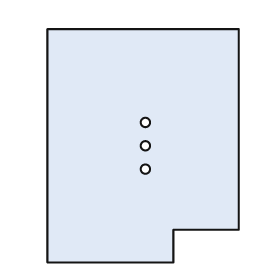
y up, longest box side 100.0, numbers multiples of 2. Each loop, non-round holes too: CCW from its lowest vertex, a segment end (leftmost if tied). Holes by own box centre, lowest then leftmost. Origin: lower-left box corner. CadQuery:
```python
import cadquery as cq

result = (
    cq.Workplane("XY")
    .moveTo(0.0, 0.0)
    .lineTo(54.0, 0.0)
    .lineTo(54.0, 14.0)
    .lineTo(82.0, 14.0)
    .lineTo(82.0, 100.0)
    .lineTo(0.0, 100.0)
    .close()
    .moveTo(42.0, 40.0)
    .circle(2.0)
    .moveTo(42.0, 50.0)
    .circle(2.0)
    .moveTo(42.0, 60.0)
    .circle(2.0)
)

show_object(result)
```